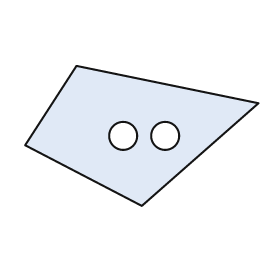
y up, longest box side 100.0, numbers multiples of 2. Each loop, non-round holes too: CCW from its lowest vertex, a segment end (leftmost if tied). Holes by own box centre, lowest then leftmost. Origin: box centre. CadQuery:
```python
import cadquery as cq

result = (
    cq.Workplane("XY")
    .moveTo(0.0, -30.0)
    .lineTo(50.0, 14.0)
    .lineTo(-28.0, 30.0)
    .lineTo(-50.0, -4.0)
    .close()
    .moveTo(-8.0, 0.0)
    .circle(6.0)
    .moveTo(10.0, 0.0)
    .circle(6.0)
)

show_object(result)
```